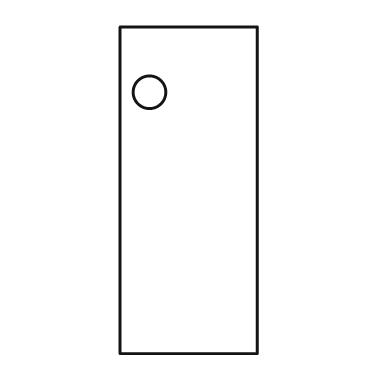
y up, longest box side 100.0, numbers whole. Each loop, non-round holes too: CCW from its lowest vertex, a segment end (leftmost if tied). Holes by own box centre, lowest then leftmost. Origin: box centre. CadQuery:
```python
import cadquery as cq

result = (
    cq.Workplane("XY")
    .moveTo(-21.0, -50.0)
    .lineTo(21.0, -50.0)
    .lineTo(21.0, 50.0)
    .lineTo(-21.0, 50.0)
    .close()
    .moveTo(-12.0, 30.0)
    .circle(5.0)
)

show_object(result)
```